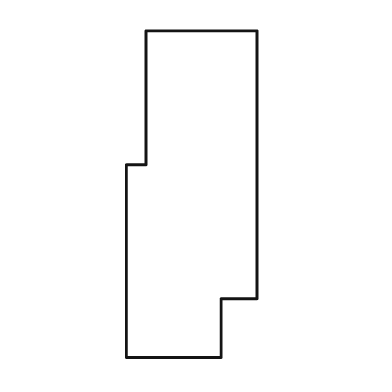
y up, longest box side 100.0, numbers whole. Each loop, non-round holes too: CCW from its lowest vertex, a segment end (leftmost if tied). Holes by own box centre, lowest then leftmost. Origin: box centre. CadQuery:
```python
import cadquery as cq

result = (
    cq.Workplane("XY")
    .moveTo(-20.0, -50.0)
    .lineTo(9.0, -50.0)
    .lineTo(9.0, -32.0)
    .lineTo(20.0, -32.0)
    .lineTo(20.0, 50.0)
    .lineTo(-14.0, 50.0)
    .lineTo(-14.0, 9.0)
    .lineTo(-20.0, 9.0)
    .close()
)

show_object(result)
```